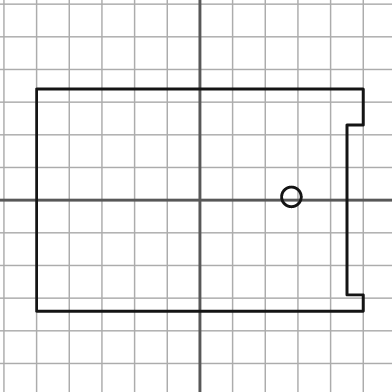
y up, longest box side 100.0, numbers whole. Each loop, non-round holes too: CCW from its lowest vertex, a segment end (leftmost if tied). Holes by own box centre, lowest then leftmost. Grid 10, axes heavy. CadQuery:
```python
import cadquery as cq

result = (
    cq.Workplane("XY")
    .moveTo(-50.0, -34.0)
    .lineTo(50.0, -34.0)
    .lineTo(50.0, -29.0)
    .lineTo(45.0, -29.0)
    .lineTo(45.0, 23.0)
    .lineTo(50.0, 23.0)
    .lineTo(50.0, 34.0)
    .lineTo(-50.0, 34.0)
    .close()
    .moveTo(28.0, 1.0)
    .circle(3.0)
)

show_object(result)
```